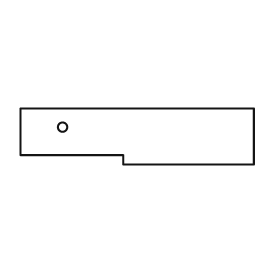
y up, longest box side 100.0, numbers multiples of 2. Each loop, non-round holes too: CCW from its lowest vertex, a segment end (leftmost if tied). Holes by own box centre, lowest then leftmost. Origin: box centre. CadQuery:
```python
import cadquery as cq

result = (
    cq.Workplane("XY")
    .moveTo(-6.0, -12.0)
    .lineTo(50.0, -12.0)
    .lineTo(50.0, 12.0)
    .lineTo(-50.0, 12.0)
    .lineTo(-50.0, -8.0)
    .lineTo(-6.0, -8.0)
    .close()
    .moveTo(-32.0, 4.0)
    .circle(2.0)
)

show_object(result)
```